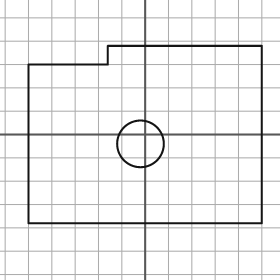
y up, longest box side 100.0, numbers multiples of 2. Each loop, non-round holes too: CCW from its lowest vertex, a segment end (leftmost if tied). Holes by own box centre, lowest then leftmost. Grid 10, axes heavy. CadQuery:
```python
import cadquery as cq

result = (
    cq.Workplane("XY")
    .moveTo(-50.0, -38.0)
    .lineTo(50.0, -38.0)
    .lineTo(50.0, 38.0)
    .lineTo(-16.0, 38.0)
    .lineTo(-16.0, 30.0)
    .lineTo(-50.0, 30.0)
    .close()
    .moveTo(-2.0, -4.0)
    .circle(10.0)
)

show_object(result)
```